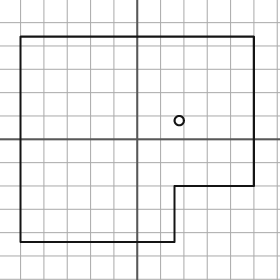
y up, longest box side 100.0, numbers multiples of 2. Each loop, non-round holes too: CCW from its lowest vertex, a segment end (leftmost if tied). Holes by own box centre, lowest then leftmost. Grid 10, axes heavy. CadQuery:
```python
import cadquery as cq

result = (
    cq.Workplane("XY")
    .moveTo(-50.0, -44.0)
    .lineTo(16.0, -44.0)
    .lineTo(16.0, -20.0)
    .lineTo(50.0, -20.0)
    .lineTo(50.0, 44.0)
    .lineTo(-50.0, 44.0)
    .close()
    .moveTo(18.0, 8.0)
    .circle(2.0)
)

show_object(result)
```